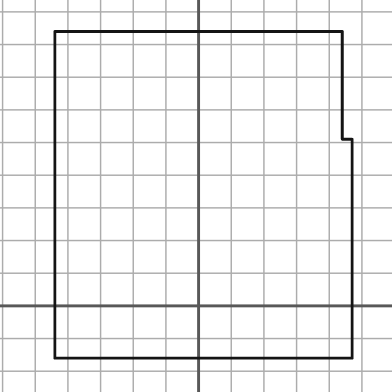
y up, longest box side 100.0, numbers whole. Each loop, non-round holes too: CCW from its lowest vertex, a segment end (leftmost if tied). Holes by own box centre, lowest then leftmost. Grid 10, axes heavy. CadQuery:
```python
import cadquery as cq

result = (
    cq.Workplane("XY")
    .moveTo(-44.0, -16.0)
    .lineTo(47.0, -16.0)
    .lineTo(47.0, 51.0)
    .lineTo(44.0, 51.0)
    .lineTo(44.0, 84.0)
    .lineTo(-44.0, 84.0)
    .close()
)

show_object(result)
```